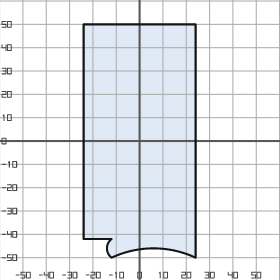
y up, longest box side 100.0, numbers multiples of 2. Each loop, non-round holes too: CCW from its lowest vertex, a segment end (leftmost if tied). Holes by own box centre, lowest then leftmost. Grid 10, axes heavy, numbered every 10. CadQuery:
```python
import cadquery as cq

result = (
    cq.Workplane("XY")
    .moveTo(-12.0, -50.0)
    .threePointArc((6.0, -46.0), (24.0, -50.0))
    .lineTo(24.0, 50.0)
    .lineTo(-24.0, 50.0)
    .lineTo(-24.0, -42.0)
    .lineTo(-12.0, -42.0)
    .threePointArc((-14.0, -46.0), (-12.0, -50.0))
    .close()
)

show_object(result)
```